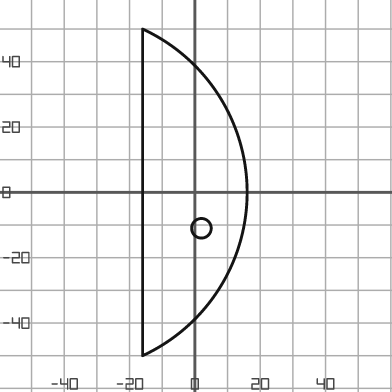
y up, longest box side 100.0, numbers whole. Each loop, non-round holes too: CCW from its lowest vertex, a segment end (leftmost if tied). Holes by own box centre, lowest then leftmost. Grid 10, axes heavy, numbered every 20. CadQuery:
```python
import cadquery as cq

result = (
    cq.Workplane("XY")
    .moveTo(-16.0, -50.0)
    .threePointArc((16.0, 0.0), (-16.0, 50.0))
    .close()
    .moveTo(2.0, -11.0)
    .circle(3.0)
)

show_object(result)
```